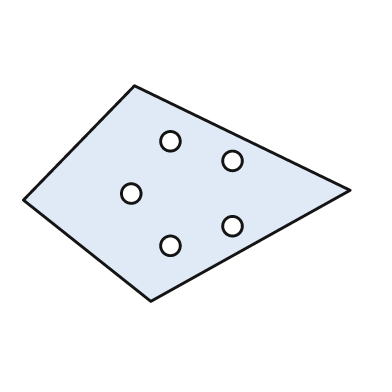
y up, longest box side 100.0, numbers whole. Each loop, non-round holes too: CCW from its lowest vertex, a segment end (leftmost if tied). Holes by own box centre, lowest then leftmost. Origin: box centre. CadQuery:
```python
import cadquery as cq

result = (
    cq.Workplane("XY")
    .moveTo(-11.0, -33.0)
    .lineTo(50.0, 1.0)
    .lineTo(-16.0, 33.0)
    .lineTo(-50.0, -2.0)
    .close()
    .moveTo(-5.0, -16.0)
    .circle(3.0)
    .moveTo(14.0, -10.0)
    .circle(3.0)
    .moveTo(-17.0, 0.0)
    .circle(3.0)
    .moveTo(14.0, 10.0)
    .circle(3.0)
    .moveTo(-5.0, 16.0)
    .circle(3.0)
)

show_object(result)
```